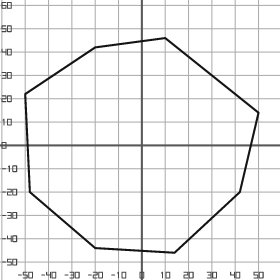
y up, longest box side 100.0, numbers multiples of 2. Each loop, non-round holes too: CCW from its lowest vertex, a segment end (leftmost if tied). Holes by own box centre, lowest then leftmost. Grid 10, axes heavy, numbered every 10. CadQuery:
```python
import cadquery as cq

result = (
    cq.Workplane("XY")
    .moveTo(14.0, -46.0)
    .lineTo(42.0, -20.0)
    .lineTo(50.0, 14.0)
    .lineTo(10.0, 46.0)
    .lineTo(-20.0, 42.0)
    .lineTo(-50.0, 22.0)
    .lineTo(-48.0, -20.0)
    .lineTo(-20.0, -44.0)
    .close()
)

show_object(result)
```